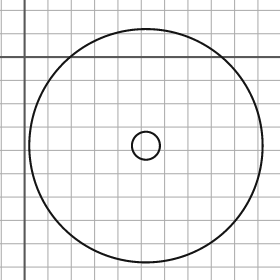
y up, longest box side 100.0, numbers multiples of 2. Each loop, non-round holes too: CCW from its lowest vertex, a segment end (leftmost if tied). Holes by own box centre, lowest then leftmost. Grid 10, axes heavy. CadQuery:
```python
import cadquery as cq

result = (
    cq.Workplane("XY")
    .moveTo(52.0, -38.0)
    .circle(50.0)
    .moveTo(52.0, -38.0)
    .circle(6.0)
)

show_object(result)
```